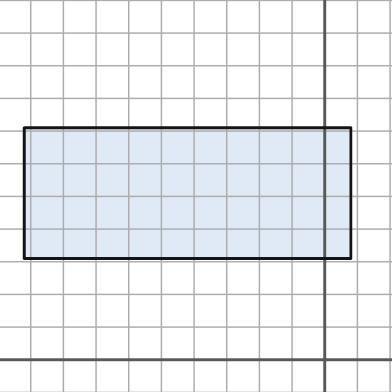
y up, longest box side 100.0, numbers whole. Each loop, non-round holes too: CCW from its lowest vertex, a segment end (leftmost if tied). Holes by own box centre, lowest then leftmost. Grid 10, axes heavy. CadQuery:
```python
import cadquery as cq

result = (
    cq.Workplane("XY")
    .moveTo(-92.0, 31.0)
    .lineTo(8.0, 31.0)
    .lineTo(8.0, 71.0)
    .lineTo(-92.0, 71.0)
    .close()
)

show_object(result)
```